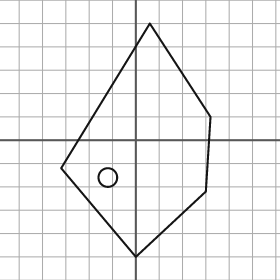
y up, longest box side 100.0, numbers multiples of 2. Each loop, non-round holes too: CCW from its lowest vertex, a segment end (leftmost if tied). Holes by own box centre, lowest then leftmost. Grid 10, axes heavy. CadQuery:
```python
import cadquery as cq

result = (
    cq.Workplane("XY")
    .moveTo(0.0, -50.0)
    .lineTo(30.0, -22.0)
    .lineTo(32.0, 10.0)
    .lineTo(6.0, 50.0)
    .lineTo(-32.0, -12.0)
    .close()
    .moveTo(-12.0, -16.0)
    .circle(4.0)
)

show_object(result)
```